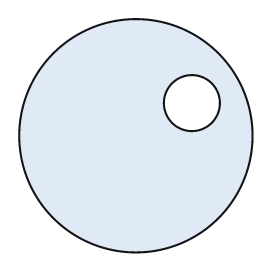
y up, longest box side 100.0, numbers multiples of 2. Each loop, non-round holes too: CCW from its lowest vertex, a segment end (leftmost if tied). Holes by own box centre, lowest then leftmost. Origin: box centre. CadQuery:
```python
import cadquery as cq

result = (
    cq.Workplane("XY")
    .moveTo(0.0, 0.0)
    .circle(50.0)
    .moveTo(24.0, 14.0)
    .circle(12.0)
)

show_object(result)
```